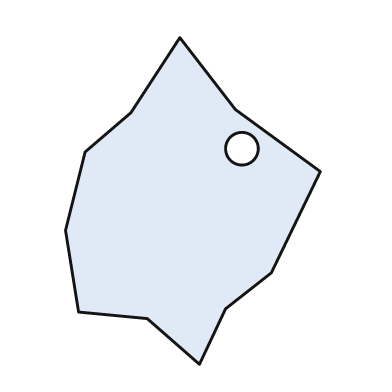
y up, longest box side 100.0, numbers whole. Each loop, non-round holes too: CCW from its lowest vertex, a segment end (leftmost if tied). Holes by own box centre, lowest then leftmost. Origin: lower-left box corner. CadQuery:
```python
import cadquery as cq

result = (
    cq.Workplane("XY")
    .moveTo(41.0, 0.0)
    .lineTo(49.0, 17.0)
    .lineTo(63.0, 28.0)
    .lineTo(78.0, 59.0)
    .lineTo(52.0, 78.0)
    .lineTo(35.0, 100.0)
    .lineTo(20.0, 77.0)
    .lineTo(6.0, 65.0)
    .lineTo(0.0, 41.0)
    .lineTo(4.0, 16.0)
    .lineTo(25.0, 14.0)
    .close()
    .moveTo(54.0, 66.0)
    .circle(5.0)
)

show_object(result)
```